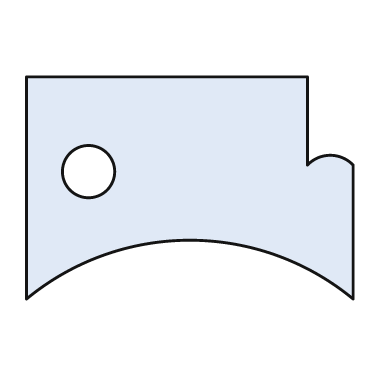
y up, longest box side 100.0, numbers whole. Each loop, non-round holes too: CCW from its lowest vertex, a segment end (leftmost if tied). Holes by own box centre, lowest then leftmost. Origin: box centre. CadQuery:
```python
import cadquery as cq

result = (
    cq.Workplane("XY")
    .moveTo(-50.0, -34.0)
    .threePointArc((0.0, -16.0), (50.0, -34.0))
    .lineTo(50.0, 7.0)
    .threePointArc((43.0, 10.0), (36.0, 7.0))
    .lineTo(36.0, 34.0)
    .lineTo(-50.0, 34.0)
    .close()
    .moveTo(-31.0, 5.0)
    .circle(8.0)
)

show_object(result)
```